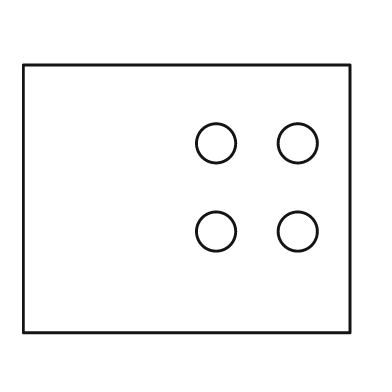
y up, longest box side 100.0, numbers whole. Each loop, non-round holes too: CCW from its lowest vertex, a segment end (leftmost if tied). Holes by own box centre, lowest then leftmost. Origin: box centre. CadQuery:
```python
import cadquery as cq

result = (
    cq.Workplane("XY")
    .moveTo(-50.0, -41.0)
    .lineTo(50.0, -41.0)
    .lineTo(50.0, 41.0)
    .lineTo(-50.0, 41.0)
    .close()
    .moveTo(9.0, -10.0)
    .circle(6.0)
    .moveTo(34.0, -10.0)
    .circle(6.0)
    .moveTo(9.0, 17.0)
    .circle(6.0)
    .moveTo(34.0, 17.0)
    .circle(6.0)
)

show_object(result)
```